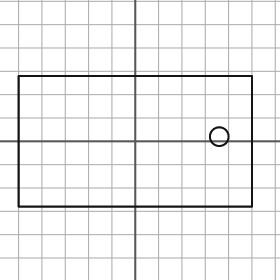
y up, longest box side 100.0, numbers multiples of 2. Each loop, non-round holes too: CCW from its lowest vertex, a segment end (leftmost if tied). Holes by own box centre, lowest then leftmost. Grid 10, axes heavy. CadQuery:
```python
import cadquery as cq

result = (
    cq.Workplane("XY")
    .moveTo(-50.0, -28.0)
    .lineTo(50.0, -28.0)
    .lineTo(50.0, 28.0)
    .lineTo(-50.0, 28.0)
    .close()
    .moveTo(36.0, 2.0)
    .circle(4.0)
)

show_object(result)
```